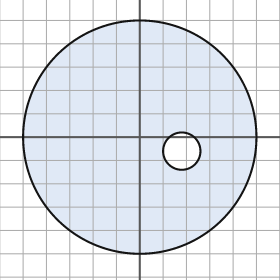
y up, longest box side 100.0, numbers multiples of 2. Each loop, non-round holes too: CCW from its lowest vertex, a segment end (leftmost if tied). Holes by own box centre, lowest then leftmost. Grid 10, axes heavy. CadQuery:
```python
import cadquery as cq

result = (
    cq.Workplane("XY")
    .moveTo(0.0, 0.0)
    .circle(50.0)
    .moveTo(18.0, -6.0)
    .circle(8.0)
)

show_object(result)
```